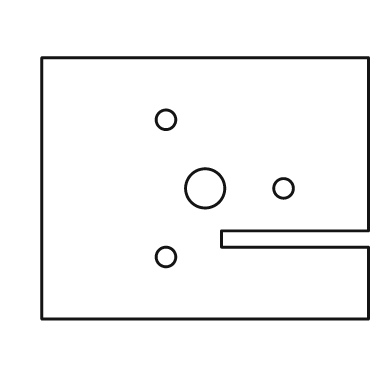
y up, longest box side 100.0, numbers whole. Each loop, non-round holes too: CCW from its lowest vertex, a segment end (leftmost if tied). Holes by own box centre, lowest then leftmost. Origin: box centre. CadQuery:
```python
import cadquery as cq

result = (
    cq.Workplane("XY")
    .moveTo(-50.0, -40.0)
    .lineTo(50.0, -40.0)
    .lineTo(50.0, -18.0)
    .lineTo(5.0, -18.0)
    .lineTo(5.0, -13.0)
    .lineTo(50.0, -13.0)
    .lineTo(50.0, 40.0)
    .lineTo(-50.0, 40.0)
    .close()
    .moveTo(-12.0, -21.0)
    .circle(3.0)
    .moveTo(0.0, 0.0)
    .circle(6.0)
    .moveTo(24.0, 0.0)
    .circle(3.0)
    .moveTo(-12.0, 21.0)
    .circle(3.0)
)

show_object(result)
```